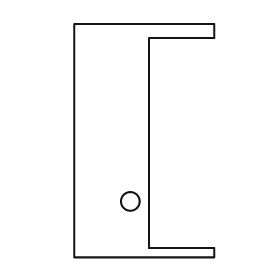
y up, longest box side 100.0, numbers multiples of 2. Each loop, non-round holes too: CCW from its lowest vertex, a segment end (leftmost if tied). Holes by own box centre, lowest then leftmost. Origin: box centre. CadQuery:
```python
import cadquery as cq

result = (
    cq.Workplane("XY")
    .moveTo(-30.0, -50.0)
    .lineTo(30.0, -50.0)
    .lineTo(30.0, -46.0)
    .lineTo(2.0, -46.0)
    .lineTo(2.0, 44.0)
    .lineTo(30.0, 44.0)
    .lineTo(30.0, 50.0)
    .lineTo(-30.0, 50.0)
    .close()
    .moveTo(-6.0, -26.0)
    .circle(4.0)
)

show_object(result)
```